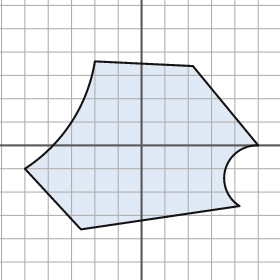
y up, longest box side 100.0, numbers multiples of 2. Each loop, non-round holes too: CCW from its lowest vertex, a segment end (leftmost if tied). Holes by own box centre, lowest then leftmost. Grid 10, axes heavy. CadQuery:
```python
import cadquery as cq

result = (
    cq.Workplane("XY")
    .moveTo(-26.0, -36.0)
    .lineTo(42.0, -26.0)
    .threePointArc((36.0, -10.0), (50.0, 0.0))
    .lineTo(22.0, 34.0)
    .lineTo(-20.0, 36.0)
    .threePointArc((-30.0, 10.0), (-50.0, -10.0))
    .close()
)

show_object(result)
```